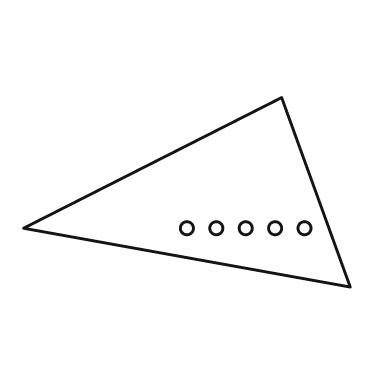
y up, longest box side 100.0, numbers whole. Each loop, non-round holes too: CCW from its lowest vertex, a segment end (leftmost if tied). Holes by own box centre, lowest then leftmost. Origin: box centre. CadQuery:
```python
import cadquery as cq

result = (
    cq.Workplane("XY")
    .moveTo(50.0, -29.0)
    .lineTo(29.0, 29.0)
    .lineTo(-50.0, -11.0)
    .close()
    .moveTo(0.0, -11.0)
    .circle(2.0)
    .moveTo(9.0, -11.0)
    .circle(2.0)
    .moveTo(18.0, -11.0)
    .circle(2.0)
    .moveTo(27.0, -11.0)
    .circle(2.0)
    .moveTo(36.0, -11.0)
    .circle(2.0)
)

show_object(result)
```